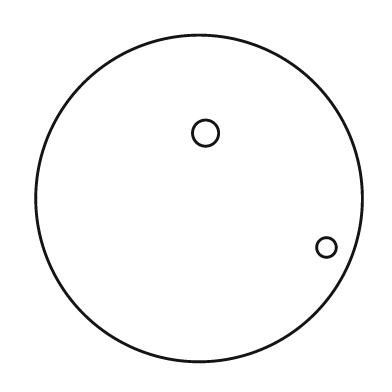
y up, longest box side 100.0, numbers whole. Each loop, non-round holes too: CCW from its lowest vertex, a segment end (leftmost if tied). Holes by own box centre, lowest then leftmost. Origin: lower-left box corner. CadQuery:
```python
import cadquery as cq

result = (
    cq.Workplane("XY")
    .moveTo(50.0, 50.0)
    .circle(50.0)
    .moveTo(89.0, 35.0)
    .circle(3.0)
    .moveTo(52.0, 70.0)
    .circle(4.0)
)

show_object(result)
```